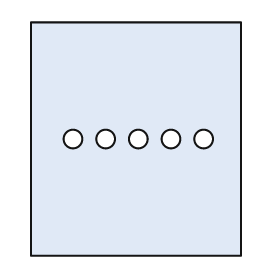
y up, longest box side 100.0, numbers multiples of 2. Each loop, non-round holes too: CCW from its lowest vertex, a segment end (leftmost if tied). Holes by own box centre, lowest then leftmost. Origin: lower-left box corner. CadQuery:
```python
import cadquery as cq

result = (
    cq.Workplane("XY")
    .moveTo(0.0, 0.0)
    .lineTo(90.0, 0.0)
    .lineTo(90.0, 100.0)
    .lineTo(0.0, 100.0)
    .close()
    .moveTo(18.0, 50.0)
    .circle(4.0)
    .moveTo(32.0, 50.0)
    .circle(4.0)
    .moveTo(46.0, 50.0)
    .circle(4.0)
    .moveTo(60.0, 50.0)
    .circle(4.0)
    .moveTo(74.0, 50.0)
    .circle(4.0)
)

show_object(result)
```